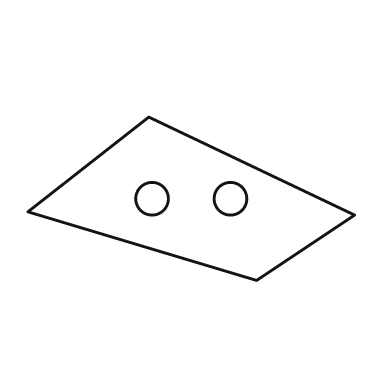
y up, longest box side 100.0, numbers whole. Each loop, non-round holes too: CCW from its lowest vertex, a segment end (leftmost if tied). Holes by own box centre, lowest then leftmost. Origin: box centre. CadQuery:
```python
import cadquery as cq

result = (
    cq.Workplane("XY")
    .moveTo(20.0, -25.0)
    .lineTo(50.0, -5.0)
    .lineTo(-13.0, 25.0)
    .lineTo(-50.0, -4.0)
    .close()
    .moveTo(-12.0, 0.0)
    .circle(5.0)
    .moveTo(12.0, 0.0)
    .circle(5.0)
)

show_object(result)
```